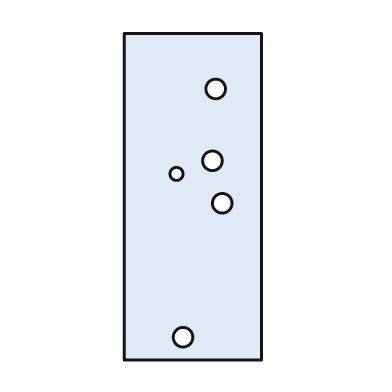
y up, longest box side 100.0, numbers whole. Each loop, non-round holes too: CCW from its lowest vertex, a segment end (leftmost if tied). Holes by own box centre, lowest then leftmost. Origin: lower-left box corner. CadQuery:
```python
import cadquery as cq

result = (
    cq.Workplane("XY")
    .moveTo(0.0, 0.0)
    .lineTo(42.0, 0.0)
    .lineTo(42.0, 100.0)
    .lineTo(0.0, 100.0)
    .close()
    .moveTo(18.0, 7.0)
    .circle(3.0)
    .moveTo(30.0, 48.0)
    .circle(3.0)
    .moveTo(16.0, 57.0)
    .circle(2.0)
    .moveTo(27.0, 61.0)
    .circle(3.0)
    .moveTo(28.0, 83.0)
    .circle(3.0)
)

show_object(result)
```